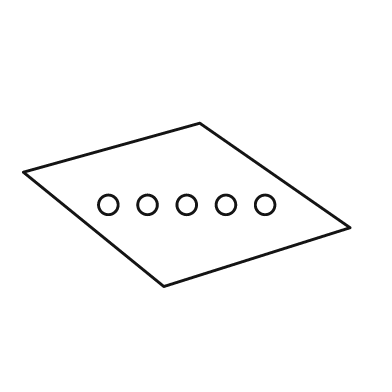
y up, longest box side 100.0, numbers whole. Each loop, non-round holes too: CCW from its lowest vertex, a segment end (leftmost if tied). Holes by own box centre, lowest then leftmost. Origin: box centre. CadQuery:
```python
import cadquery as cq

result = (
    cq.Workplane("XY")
    .moveTo(-7.0, -25.0)
    .lineTo(50.0, -7.0)
    .lineTo(4.0, 25.0)
    .lineTo(-50.0, 10.0)
    .close()
    .moveTo(-24.0, 0.0)
    .circle(3.0)
    .moveTo(-12.0, 0.0)
    .circle(3.0)
    .moveTo(0.0, 0.0)
    .circle(3.0)
    .moveTo(12.0, 0.0)
    .circle(3.0)
    .moveTo(24.0, 0.0)
    .circle(3.0)
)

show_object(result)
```